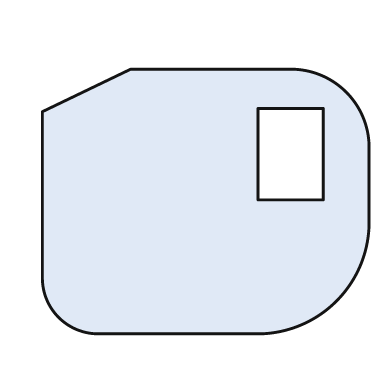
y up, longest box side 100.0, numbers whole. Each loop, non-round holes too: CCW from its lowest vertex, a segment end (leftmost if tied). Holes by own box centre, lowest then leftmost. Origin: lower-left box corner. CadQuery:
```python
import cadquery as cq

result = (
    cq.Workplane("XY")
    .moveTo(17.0, 0.0)
    .lineTo(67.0, 0.0)
    .threePointArc((90.0, 10.0), (100.0, 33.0))
    .lineTo(100.0, 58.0)
    .threePointArc((93.0, 74.0), (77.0, 81.0))
    .lineTo(27.0, 81.0)
    .lineTo(0.0, 68.0)
    .lineTo(0.0, 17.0)
    .threePointArc((5.0, 5.0), (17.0, 0.0))
    .close()
    .moveTo(66.0, 41.0)
    .lineTo(86.0, 41.0)
    .lineTo(86.0, 69.0)
    .lineTo(66.0, 69.0)
    .close()
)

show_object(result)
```